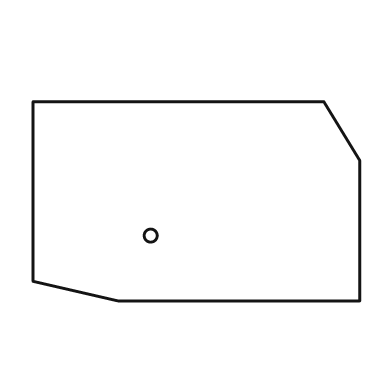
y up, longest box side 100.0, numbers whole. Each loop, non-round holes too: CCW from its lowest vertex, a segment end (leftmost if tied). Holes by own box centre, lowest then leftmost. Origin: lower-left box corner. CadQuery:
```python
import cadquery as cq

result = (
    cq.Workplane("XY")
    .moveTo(26.0, 0.0)
    .lineTo(100.0, 0.0)
    .lineTo(100.0, 43.0)
    .lineTo(89.0, 61.0)
    .lineTo(0.0, 61.0)
    .lineTo(0.0, 6.0)
    .close()
    .moveTo(36.0, 20.0)
    .circle(2.0)
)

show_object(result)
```